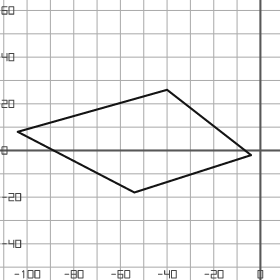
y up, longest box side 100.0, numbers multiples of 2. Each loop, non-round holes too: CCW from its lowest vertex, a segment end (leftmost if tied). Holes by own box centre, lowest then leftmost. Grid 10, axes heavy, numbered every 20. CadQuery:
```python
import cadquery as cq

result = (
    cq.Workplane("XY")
    .moveTo(-54.0, -18.0)
    .lineTo(-4.0, -2.0)
    .lineTo(-40.0, 26.0)
    .lineTo(-104.0, 8.0)
    .close()
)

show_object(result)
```